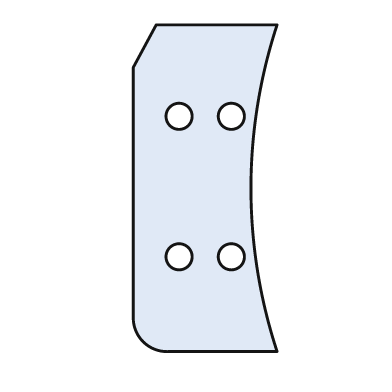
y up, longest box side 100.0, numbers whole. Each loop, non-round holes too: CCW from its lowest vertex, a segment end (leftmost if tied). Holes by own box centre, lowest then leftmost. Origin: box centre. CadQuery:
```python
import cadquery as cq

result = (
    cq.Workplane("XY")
    .moveTo(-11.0, -50.0)
    .lineTo(22.0, -50.0)
    .threePointArc((14.0, 0.0), (22.0, 50.0))
    .lineTo(-15.0, 50.0)
    .lineTo(-22.0, 37.0)
    .lineTo(-22.0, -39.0)
    .threePointArc((-19.0, -47.0), (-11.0, -50.0))
    .close()
    .moveTo(-8.0, -21.0)
    .circle(4.0)
    .moveTo(8.0, -21.0)
    .circle(4.0)
    .moveTo(-8.0, 22.0)
    .circle(4.0)
    .moveTo(8.0, 22.0)
    .circle(4.0)
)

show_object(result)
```